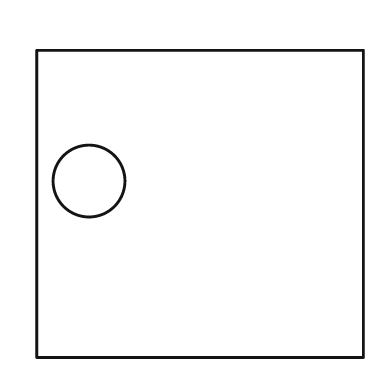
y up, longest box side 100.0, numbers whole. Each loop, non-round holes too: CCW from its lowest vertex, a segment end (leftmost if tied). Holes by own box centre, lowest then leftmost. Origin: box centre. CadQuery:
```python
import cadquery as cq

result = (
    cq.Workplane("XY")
    .moveTo(-50.0, -47.0)
    .lineTo(50.0, -47.0)
    .lineTo(50.0, 47.0)
    .lineTo(-50.0, 47.0)
    .close()
    .moveTo(-34.0, 7.0)
    .circle(11.0)
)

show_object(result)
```